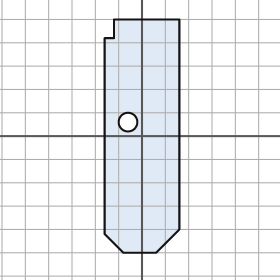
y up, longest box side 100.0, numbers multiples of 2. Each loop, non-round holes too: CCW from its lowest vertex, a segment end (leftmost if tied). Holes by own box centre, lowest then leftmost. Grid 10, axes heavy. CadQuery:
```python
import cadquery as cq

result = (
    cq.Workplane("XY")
    .moveTo(-8.0, -50.0)
    .lineTo(6.0, -50.0)
    .lineTo(16.0, -40.0)
    .lineTo(16.0, 50.0)
    .lineTo(-12.0, 50.0)
    .lineTo(-12.0, 42.0)
    .lineTo(-16.0, 42.0)
    .lineTo(-16.0, -42.0)
    .close()
    .moveTo(-6.0, 6.0)
    .circle(4.0)
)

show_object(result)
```